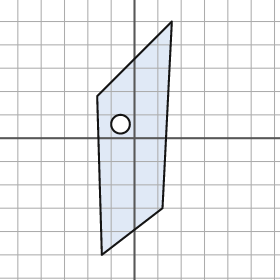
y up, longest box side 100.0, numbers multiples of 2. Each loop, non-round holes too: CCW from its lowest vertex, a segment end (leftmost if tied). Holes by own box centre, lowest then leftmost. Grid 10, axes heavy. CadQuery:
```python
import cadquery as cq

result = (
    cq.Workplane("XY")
    .moveTo(-14.0, -50.0)
    .lineTo(12.0, -30.0)
    .lineTo(16.0, 50.0)
    .lineTo(-16.0, 18.0)
    .close()
    .moveTo(-6.0, 6.0)
    .circle(4.0)
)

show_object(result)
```